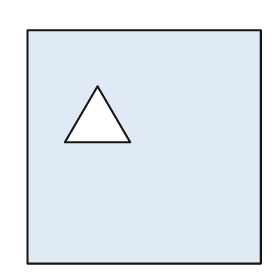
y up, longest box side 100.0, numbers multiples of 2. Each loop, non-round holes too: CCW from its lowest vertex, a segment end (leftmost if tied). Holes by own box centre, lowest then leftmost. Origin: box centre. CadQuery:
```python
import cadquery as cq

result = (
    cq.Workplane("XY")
    .moveTo(-50.0, -50.0)
    .lineTo(50.0, -50.0)
    .lineTo(50.0, 50.0)
    .lineTo(-50.0, 50.0)
    .close()
    .moveTo(-34.0, 2.0)
    .lineTo(-6.0, 2.0)
    .lineTo(-20.0, 26.0)
    .close()
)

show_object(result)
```